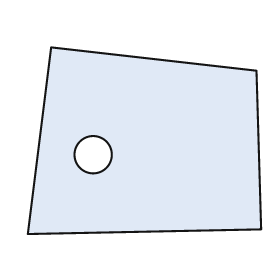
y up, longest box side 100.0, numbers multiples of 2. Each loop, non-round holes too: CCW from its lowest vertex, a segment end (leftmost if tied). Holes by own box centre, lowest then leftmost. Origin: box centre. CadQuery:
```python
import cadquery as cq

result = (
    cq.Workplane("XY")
    .moveTo(-50.0, -40.0)
    .lineTo(50.0, -38.0)
    .lineTo(48.0, 30.0)
    .lineTo(-40.0, 40.0)
    .close()
    .moveTo(-22.0, -6.0)
    .circle(8.0)
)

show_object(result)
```